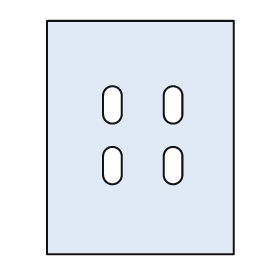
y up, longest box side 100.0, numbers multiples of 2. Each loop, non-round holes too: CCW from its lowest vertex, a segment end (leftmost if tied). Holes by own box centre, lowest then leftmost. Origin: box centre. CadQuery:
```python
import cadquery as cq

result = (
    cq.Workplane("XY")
    .moveTo(-40.0, -50.0)
    .lineTo(40.0, -50.0)
    .lineTo(40.0, 50.0)
    .lineTo(-40.0, 50.0)
    .close()
    .moveTo(-16.0, -16.0)
    .threePointArc((-12.0, -20.0), (-8.0, -16.0))
    .lineTo(-8.0, -8.0)
    .threePointArc((-12.0, -4.0), (-16.0, -8.0))
    .close()
    .moveTo(10.0, -16.0)
    .threePointArc((14.0, -20.0), (18.0, -16.0))
    .lineTo(18.0, -8.0)
    .threePointArc((14.0, -4.0), (10.0, -8.0))
    .close()
    .moveTo(-16.0, 10.0)
    .threePointArc((-12.0, 6.0), (-8.0, 10.0))
    .lineTo(-8.0, 18.0)
    .threePointArc((-12.0, 22.0), (-16.0, 18.0))
    .close()
    .moveTo(10.0, 10.0)
    .threePointArc((14.0, 6.0), (18.0, 10.0))
    .lineTo(18.0, 18.0)
    .threePointArc((14.0, 22.0), (10.0, 18.0))
    .close()
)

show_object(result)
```